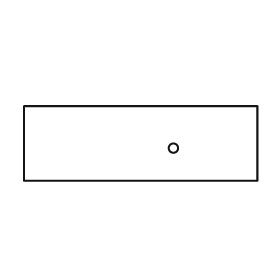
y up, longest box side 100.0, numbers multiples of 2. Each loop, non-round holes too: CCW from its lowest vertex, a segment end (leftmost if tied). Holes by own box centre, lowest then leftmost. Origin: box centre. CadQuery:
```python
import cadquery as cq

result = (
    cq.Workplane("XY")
    .moveTo(-50.0, -16.0)
    .lineTo(50.0, -16.0)
    .lineTo(50.0, 16.0)
    .lineTo(-50.0, 16.0)
    .close()
    .moveTo(14.0, -2.0)
    .circle(2.0)
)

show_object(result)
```